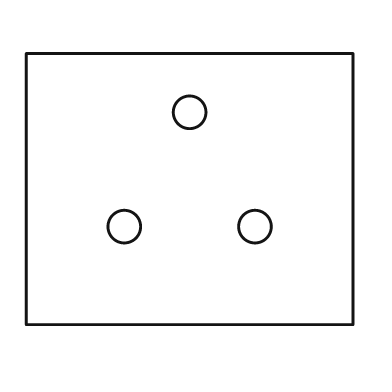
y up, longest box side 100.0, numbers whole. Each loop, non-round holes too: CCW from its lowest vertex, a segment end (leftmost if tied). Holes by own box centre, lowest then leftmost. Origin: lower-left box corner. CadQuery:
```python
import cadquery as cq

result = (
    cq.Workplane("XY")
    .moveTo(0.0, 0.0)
    .lineTo(100.0, 0.0)
    .lineTo(100.0, 83.0)
    .lineTo(0.0, 83.0)
    .close()
    .moveTo(30.0, 30.0)
    .circle(5.0)
    .moveTo(70.0, 30.0)
    .circle(5.0)
    .moveTo(50.0, 65.0)
    .circle(5.0)
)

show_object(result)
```